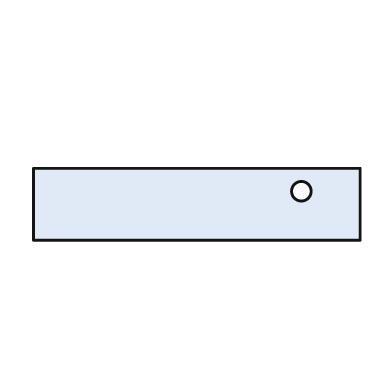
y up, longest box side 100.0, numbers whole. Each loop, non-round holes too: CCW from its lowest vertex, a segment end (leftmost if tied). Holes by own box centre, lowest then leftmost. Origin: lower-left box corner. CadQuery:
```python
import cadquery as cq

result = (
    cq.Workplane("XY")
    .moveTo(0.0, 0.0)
    .lineTo(100.0, 0.0)
    .lineTo(100.0, 22.0)
    .lineTo(0.0, 22.0)
    .close()
    .moveTo(82.0, 15.0)
    .circle(3.0)
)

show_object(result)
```